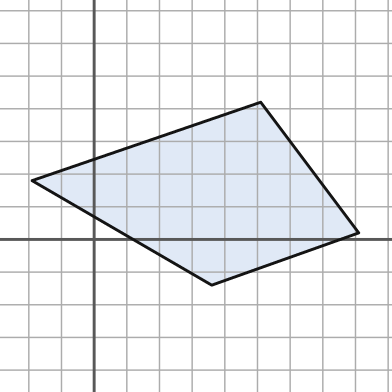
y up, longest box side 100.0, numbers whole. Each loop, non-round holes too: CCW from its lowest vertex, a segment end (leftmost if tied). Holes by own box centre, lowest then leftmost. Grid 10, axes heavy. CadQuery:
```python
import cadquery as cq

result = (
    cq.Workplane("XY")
    .moveTo(36.0, -14.0)
    .lineTo(81.0, 2.0)
    .lineTo(51.0, 42.0)
    .lineTo(-19.0, 18.0)
    .close()
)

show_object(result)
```